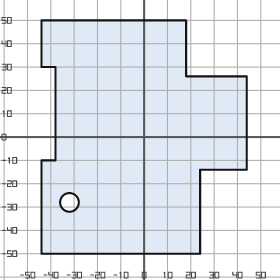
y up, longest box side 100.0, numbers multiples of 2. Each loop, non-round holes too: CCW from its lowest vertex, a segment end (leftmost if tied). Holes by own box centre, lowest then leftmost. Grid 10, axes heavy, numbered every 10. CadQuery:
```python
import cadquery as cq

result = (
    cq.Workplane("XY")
    .moveTo(-44.0, -50.0)
    .lineTo(24.0, -50.0)
    .lineTo(24.0, -14.0)
    .lineTo(44.0, -14.0)
    .lineTo(44.0, 26.0)
    .lineTo(18.0, 26.0)
    .lineTo(18.0, 50.0)
    .lineTo(-44.0, 50.0)
    .lineTo(-44.0, 30.0)
    .lineTo(-38.0, 30.0)
    .lineTo(-38.0, -10.0)
    .lineTo(-44.0, -10.0)
    .close()
    .moveTo(-32.0, -28.0)
    .circle(4.0)
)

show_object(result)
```